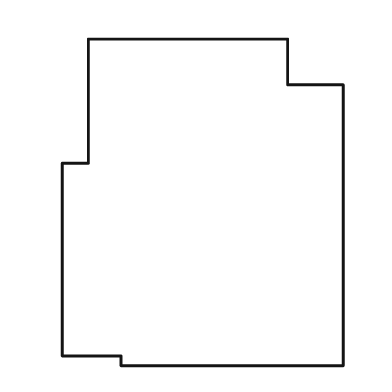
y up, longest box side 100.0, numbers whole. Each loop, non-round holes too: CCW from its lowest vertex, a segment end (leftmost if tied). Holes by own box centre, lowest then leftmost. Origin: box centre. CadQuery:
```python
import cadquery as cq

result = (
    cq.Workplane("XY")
    .moveTo(-25.0, -50.0)
    .lineTo(43.0, -50.0)
    .lineTo(43.0, 36.0)
    .lineTo(26.0, 36.0)
    .lineTo(26.0, 50.0)
    .lineTo(-35.0, 50.0)
    .lineTo(-35.0, 12.0)
    .lineTo(-43.0, 12.0)
    .lineTo(-43.0, -47.0)
    .lineTo(-25.0, -47.0)
    .close()
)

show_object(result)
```